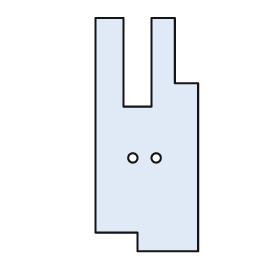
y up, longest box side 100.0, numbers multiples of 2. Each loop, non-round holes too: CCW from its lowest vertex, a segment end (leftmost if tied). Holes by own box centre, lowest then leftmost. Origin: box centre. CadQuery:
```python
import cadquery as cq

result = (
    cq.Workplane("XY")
    .moveTo(-4.0, -50.0)
    .lineTo(22.0, -50.0)
    .lineTo(22.0, 22.0)
    .lineTo(12.0, 22.0)
    .lineTo(12.0, 50.0)
    .lineTo(2.0, 50.0)
    .lineTo(2.0, 12.0)
    .lineTo(-10.0, 12.0)
    .lineTo(-10.0, 50.0)
    .lineTo(-22.0, 50.0)
    .lineTo(-22.0, -42.0)
    .lineTo(-4.0, -42.0)
    .close()
    .moveTo(-6.0, -10.0)
    .circle(2.0)
    .moveTo(4.0, -10.0)
    .circle(2.0)
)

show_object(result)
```